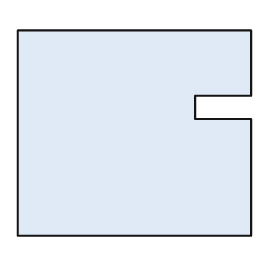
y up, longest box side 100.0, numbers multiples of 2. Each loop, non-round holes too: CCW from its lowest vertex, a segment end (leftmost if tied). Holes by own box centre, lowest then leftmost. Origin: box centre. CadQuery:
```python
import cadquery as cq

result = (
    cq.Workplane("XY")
    .moveTo(-50.0, -44.0)
    .lineTo(50.0, -44.0)
    .lineTo(50.0, 6.0)
    .lineTo(26.0, 6.0)
    .lineTo(26.0, 16.0)
    .lineTo(50.0, 16.0)
    .lineTo(50.0, 44.0)
    .lineTo(-50.0, 44.0)
    .close()
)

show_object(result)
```